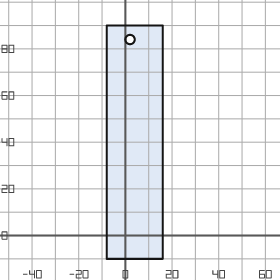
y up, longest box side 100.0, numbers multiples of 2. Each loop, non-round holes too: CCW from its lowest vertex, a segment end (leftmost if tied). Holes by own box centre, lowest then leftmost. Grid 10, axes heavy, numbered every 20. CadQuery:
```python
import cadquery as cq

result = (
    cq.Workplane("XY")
    .moveTo(-8.0, -10.0)
    .lineTo(16.0, -10.0)
    .lineTo(16.0, 90.0)
    .lineTo(-8.0, 90.0)
    .close()
    .moveTo(2.0, 84.0)
    .circle(2.0)
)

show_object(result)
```